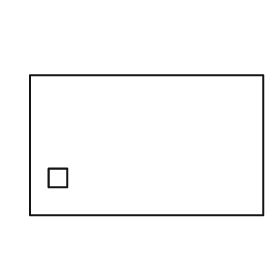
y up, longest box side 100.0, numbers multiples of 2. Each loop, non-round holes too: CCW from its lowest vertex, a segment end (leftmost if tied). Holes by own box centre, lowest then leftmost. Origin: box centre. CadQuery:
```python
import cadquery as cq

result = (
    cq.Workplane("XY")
    .moveTo(-50.0, -30.0)
    .lineTo(50.0, -30.0)
    .lineTo(50.0, 30.0)
    .lineTo(-50.0, 30.0)
    .close()
    .moveTo(-42.0, -18.0)
    .lineTo(-34.0, -18.0)
    .lineTo(-34.0, -10.0)
    .lineTo(-42.0, -10.0)
    .close()
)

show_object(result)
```